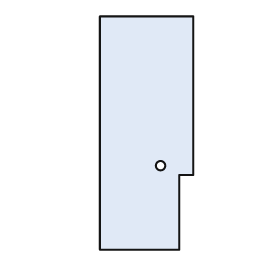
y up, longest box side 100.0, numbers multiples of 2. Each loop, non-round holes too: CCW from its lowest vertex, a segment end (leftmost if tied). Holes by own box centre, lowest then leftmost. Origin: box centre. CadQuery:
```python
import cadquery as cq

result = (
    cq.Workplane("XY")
    .moveTo(-20.0, -50.0)
    .lineTo(14.0, -50.0)
    .lineTo(14.0, -18.0)
    .lineTo(20.0, -18.0)
    .lineTo(20.0, 50.0)
    .lineTo(-20.0, 50.0)
    .close()
    .moveTo(6.0, -14.0)
    .circle(2.0)
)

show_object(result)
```